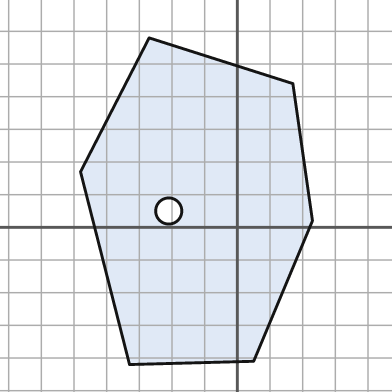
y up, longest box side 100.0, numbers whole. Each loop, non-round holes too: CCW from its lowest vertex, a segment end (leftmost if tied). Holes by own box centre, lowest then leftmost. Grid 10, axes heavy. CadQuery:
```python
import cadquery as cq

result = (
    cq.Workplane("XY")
    .moveTo(-33.0, -42.0)
    .lineTo(5.0, -41.0)
    .lineTo(23.0, 2.0)
    .lineTo(17.0, 44.0)
    .lineTo(-27.0, 58.0)
    .lineTo(-48.0, 17.0)
    .close()
    .moveTo(-21.0, 5.0)
    .circle(4.0)
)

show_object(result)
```